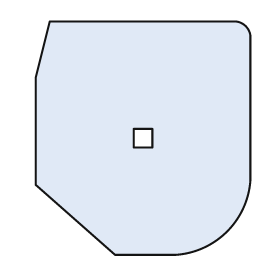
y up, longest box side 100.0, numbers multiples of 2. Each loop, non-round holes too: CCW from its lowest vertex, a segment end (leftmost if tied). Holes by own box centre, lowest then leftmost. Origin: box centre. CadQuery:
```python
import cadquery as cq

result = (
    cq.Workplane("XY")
    .moveTo(-12.0, -50.0)
    .lineTo(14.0, -50.0)
    .threePointArc((36.0, -40.0), (46.0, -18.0))
    .lineTo(46.0, 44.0)
    .threePointArc((44.0, 48.0), (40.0, 50.0))
    .lineTo(-40.0, 50.0)
    .lineTo(-46.0, 26.0)
    .lineTo(-46.0, -20.0)
    .close()
    .moveTo(-4.0, -4.0)
    .lineTo(4.0, -4.0)
    .lineTo(4.0, 4.0)
    .lineTo(-4.0, 4.0)
    .close()
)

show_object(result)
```